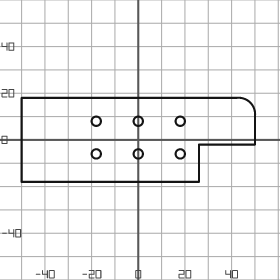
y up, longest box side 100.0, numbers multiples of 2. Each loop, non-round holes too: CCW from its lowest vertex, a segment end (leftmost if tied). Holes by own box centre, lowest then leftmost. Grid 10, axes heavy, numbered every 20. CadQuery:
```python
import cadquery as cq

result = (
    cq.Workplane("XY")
    .moveTo(-50.0, -18.0)
    .lineTo(26.0, -18.0)
    .lineTo(26.0, -2.0)
    .lineTo(50.0, -2.0)
    .lineTo(50.0, 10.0)
    .threePointArc((48.0, 16.0), (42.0, 18.0))
    .lineTo(-50.0, 18.0)
    .close()
    .moveTo(-18.0, -6.0)
    .circle(2.0)
    .moveTo(0.0, -6.0)
    .circle(2.0)
    .moveTo(18.0, -6.0)
    .circle(2.0)
    .moveTo(-18.0, 8.0)
    .circle(2.0)
    .moveTo(0.0, 8.0)
    .circle(2.0)
    .moveTo(18.0, 8.0)
    .circle(2.0)
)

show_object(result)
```